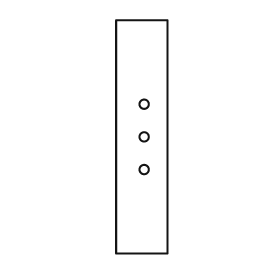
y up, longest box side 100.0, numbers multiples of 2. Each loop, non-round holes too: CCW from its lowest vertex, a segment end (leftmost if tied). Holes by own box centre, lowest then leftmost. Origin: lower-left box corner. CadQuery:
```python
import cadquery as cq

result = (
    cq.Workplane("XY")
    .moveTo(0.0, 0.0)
    .lineTo(22.0, 0.0)
    .lineTo(22.0, 100.0)
    .lineTo(0.0, 100.0)
    .close()
    .moveTo(12.0, 36.0)
    .circle(2.0)
    .moveTo(12.0, 50.0)
    .circle(2.0)
    .moveTo(12.0, 64.0)
    .circle(2.0)
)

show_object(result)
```